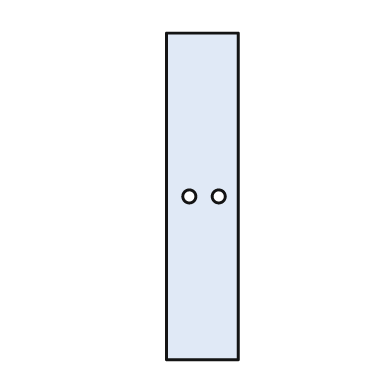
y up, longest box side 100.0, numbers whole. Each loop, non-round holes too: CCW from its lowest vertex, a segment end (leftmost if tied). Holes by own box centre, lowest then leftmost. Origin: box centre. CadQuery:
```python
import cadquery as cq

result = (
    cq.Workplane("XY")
    .moveTo(-11.0, -50.0)
    .lineTo(11.0, -50.0)
    .lineTo(11.0, 50.0)
    .lineTo(-11.0, 50.0)
    .close()
    .moveTo(-4.0, 0.0)
    .circle(2.0)
    .moveTo(5.0, 0.0)
    .circle(2.0)
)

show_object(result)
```